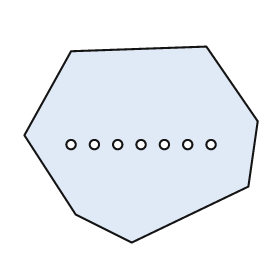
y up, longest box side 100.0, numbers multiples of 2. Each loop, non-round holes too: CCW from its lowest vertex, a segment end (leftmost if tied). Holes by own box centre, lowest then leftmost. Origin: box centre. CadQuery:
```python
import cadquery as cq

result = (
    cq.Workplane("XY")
    .moveTo(-4.0, -42.0)
    .lineTo(46.0, -18.0)
    .lineTo(50.0, 10.0)
    .lineTo(28.0, 42.0)
    .lineTo(-30.0, 40.0)
    .lineTo(-50.0, 4.0)
    .lineTo(-28.0, -30.0)
    .close()
    .moveTo(-30.0, 0.0)
    .circle(2.0)
    .moveTo(-20.0, 0.0)
    .circle(2.0)
    .moveTo(-10.0, 0.0)
    .circle(2.0)
    .moveTo(0.0, 0.0)
    .circle(2.0)
    .moveTo(10.0, 0.0)
    .circle(2.0)
    .moveTo(20.0, 0.0)
    .circle(2.0)
    .moveTo(30.0, 0.0)
    .circle(2.0)
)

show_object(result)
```